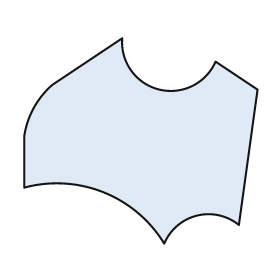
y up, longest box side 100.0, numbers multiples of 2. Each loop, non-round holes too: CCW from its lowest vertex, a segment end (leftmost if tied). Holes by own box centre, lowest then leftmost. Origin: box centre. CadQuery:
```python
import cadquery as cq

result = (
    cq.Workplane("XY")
    .moveTo(10.0, -44.0)
    .threePointArc((24.0, -32.0), (42.0, -36.0))
    .lineTo(50.0, 22.0)
    .lineTo(32.0, 34.0)
    .threePointArc((8.0, 22.0), (-8.0, 44.0))
    .lineTo(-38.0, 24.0)
    .threePointArc((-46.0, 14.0), (-50.0, 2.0))
    .lineTo(-50.0, -20.0)
    .threePointArc((-16.0, -22.0), (10.0, -44.0))
    .close()
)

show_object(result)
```